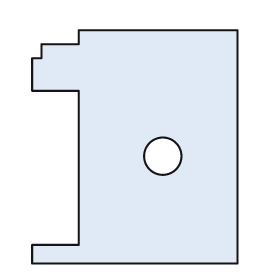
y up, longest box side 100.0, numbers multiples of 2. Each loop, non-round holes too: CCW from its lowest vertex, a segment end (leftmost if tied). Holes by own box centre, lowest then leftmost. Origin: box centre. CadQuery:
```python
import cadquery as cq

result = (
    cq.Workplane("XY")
    .moveTo(-44.0, -50.0)
    .lineTo(44.0, -50.0)
    .lineTo(44.0, 50.0)
    .lineTo(-24.0, 50.0)
    .lineTo(-24.0, 44.0)
    .lineTo(-40.0, 44.0)
    .lineTo(-40.0, 38.0)
    .lineTo(-44.0, 38.0)
    .lineTo(-44.0, 24.0)
    .lineTo(-24.0, 24.0)
    .lineTo(-24.0, -42.0)
    .lineTo(-44.0, -42.0)
    .close()
    .moveTo(12.0, -4.0)
    .circle(8.0)
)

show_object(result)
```